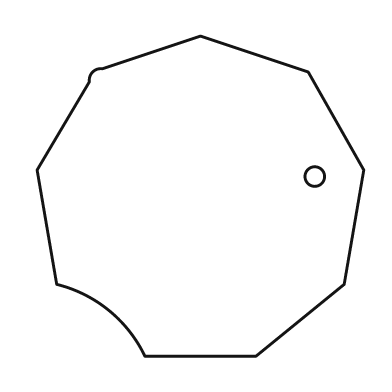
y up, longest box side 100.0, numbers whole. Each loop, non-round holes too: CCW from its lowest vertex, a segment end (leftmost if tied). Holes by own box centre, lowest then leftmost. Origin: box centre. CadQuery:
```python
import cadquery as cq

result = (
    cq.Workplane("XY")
    .moveTo(-17.0, -49.0)
    .lineTo(17.0, -49.0)
    .lineTo(44.0, -27.0)
    .lineTo(50.0, 8.0)
    .lineTo(33.0, 38.0)
    .lineTo(0.0, 49.0)
    .lineTo(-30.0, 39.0)
    .threePointArc((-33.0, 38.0), (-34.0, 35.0))
    .lineTo(-50.0, 8.0)
    .lineTo(-44.0, -27.0)
    .threePointArc((-28.0, -35.0), (-17.0, -49.0))
    .close()
    .moveTo(35.0, 6.0)
    .circle(3.0)
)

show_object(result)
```